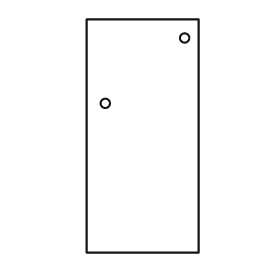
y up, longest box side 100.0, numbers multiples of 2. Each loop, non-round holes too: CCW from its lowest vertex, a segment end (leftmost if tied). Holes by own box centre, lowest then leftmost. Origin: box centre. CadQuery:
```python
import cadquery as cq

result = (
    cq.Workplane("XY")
    .moveTo(-24.0, -50.0)
    .lineTo(24.0, -50.0)
    .lineTo(24.0, 50.0)
    .lineTo(-24.0, 50.0)
    .close()
    .moveTo(-16.0, 14.0)
    .circle(2.0)
    .moveTo(18.0, 42.0)
    .circle(2.0)
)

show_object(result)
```